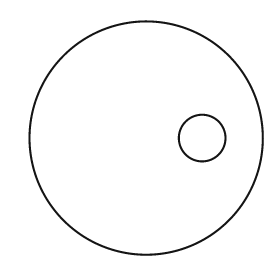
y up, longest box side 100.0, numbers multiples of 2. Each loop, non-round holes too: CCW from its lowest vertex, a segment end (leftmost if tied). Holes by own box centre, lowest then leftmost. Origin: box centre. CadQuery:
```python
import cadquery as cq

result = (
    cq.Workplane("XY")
    .moveTo(0.0, 0.0)
    .circle(50.0)
    .moveTo(24.0, 0.0)
    .circle(10.0)
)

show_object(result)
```